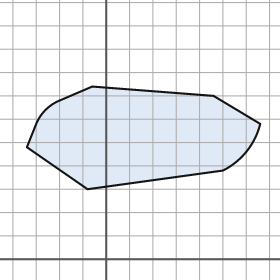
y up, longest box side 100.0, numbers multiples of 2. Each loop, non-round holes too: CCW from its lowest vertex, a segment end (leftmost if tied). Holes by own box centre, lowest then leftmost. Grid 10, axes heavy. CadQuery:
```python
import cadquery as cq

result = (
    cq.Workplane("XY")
    .moveTo(-8.0, 30.0)
    .lineTo(50.0, 38.0)
    .threePointArc((60.0, 46.0), (66.0, 58.0))
    .lineTo(46.0, 70.0)
    .lineTo(-6.0, 74.0)
    .lineTo(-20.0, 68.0)
    .threePointArc((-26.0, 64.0), (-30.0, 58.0))
    .lineTo(-34.0, 48.0)
    .close()
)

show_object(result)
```